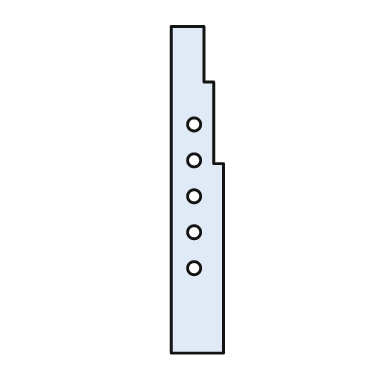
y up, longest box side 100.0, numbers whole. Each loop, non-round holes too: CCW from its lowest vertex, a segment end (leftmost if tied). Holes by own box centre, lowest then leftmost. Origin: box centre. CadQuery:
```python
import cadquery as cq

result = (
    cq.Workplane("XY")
    .moveTo(-8.0, -50.0)
    .lineTo(8.0, -50.0)
    .lineTo(8.0, 8.0)
    .lineTo(5.0, 8.0)
    .lineTo(5.0, 33.0)
    .lineTo(2.0, 33.0)
    .lineTo(2.0, 50.0)
    .lineTo(-8.0, 50.0)
    .close()
    .moveTo(-1.0, -24.0)
    .circle(2.0)
    .moveTo(-1.0, -13.0)
    .circle(2.0)
    .moveTo(-1.0, -2.0)
    .circle(2.0)
    .moveTo(-1.0, 9.0)
    .circle(2.0)
    .moveTo(-1.0, 20.0)
    .circle(2.0)
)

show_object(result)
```